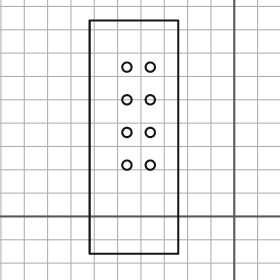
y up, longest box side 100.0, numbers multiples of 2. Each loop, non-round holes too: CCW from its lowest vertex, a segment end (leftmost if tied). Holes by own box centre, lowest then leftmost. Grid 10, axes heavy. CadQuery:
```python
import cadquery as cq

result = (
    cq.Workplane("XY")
    .moveTo(-62.0, -16.0)
    .lineTo(-24.0, -16.0)
    .lineTo(-24.0, 84.0)
    .lineTo(-62.0, 84.0)
    .close()
    .moveTo(-46.0, 22.0)
    .circle(2.0)
    .moveTo(-36.0, 22.0)
    .circle(2.0)
    .moveTo(-46.0, 36.0)
    .circle(2.0)
    .moveTo(-36.0, 36.0)
    .circle(2.0)
    .moveTo(-46.0, 50.0)
    .circle(2.0)
    .moveTo(-36.0, 50.0)
    .circle(2.0)
    .moveTo(-46.0, 64.0)
    .circle(2.0)
    .moveTo(-36.0, 64.0)
    .circle(2.0)
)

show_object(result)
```